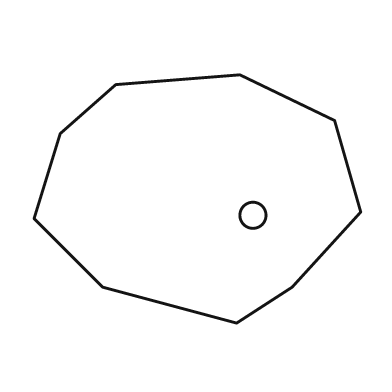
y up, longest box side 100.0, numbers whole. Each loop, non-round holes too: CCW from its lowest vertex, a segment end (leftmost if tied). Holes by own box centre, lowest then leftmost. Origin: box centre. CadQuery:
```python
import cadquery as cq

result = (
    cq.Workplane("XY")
    .moveTo(12.0, -38.0)
    .lineTo(29.0, -27.0)
    .lineTo(50.0, -4.0)
    .lineTo(42.0, 24.0)
    .lineTo(13.0, 38.0)
    .lineTo(-25.0, 35.0)
    .lineTo(-42.0, 20.0)
    .lineTo(-50.0, -6.0)
    .lineTo(-29.0, -27.0)
    .close()
    .moveTo(17.0, -5.0)
    .circle(4.0)
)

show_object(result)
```